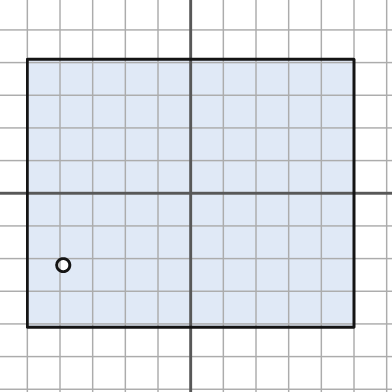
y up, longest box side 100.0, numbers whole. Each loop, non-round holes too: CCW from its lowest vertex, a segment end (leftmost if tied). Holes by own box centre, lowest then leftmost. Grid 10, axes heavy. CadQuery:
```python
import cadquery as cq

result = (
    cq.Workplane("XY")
    .moveTo(-50.0, -41.0)
    .lineTo(50.0, -41.0)
    .lineTo(50.0, 41.0)
    .lineTo(-50.0, 41.0)
    .close()
    .moveTo(-39.0, -22.0)
    .circle(2.0)
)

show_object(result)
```